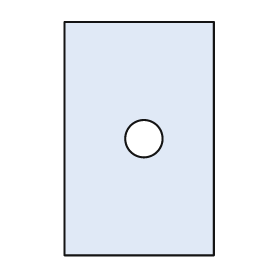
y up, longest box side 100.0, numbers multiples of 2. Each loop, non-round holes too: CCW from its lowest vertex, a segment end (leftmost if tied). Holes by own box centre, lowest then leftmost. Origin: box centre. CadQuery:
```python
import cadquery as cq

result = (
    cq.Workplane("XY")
    .moveTo(-32.0, -50.0)
    .lineTo(32.0, -50.0)
    .lineTo(32.0, 50.0)
    .lineTo(-32.0, 50.0)
    .close()
    .moveTo(2.0, 0.0)
    .circle(8.0)
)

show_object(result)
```